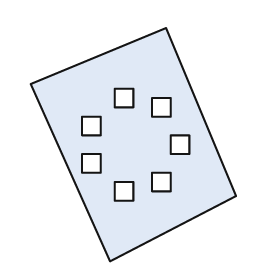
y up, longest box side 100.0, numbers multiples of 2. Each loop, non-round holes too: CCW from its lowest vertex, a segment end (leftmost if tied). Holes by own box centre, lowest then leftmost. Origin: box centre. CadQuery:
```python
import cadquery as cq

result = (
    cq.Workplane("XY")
    .moveTo(-10.0, -50.0)
    .lineTo(44.0, -22.0)
    .lineTo(14.0, 50.0)
    .lineTo(-44.0, 26.0)
    .close()
    .moveTo(-8.0, -24.0)
    .lineTo(0.0, -24.0)
    .lineTo(0.0, -16.0)
    .lineTo(-8.0, -16.0)
    .close()
    .moveTo(8.0, -20.0)
    .lineTo(16.0, -20.0)
    .lineTo(16.0, -12.0)
    .lineTo(8.0, -12.0)
    .close()
    .moveTo(-22.0, -12.0)
    .lineTo(-14.0, -12.0)
    .lineTo(-14.0, -4.0)
    .lineTo(-22.0, -4.0)
    .close()
    .moveTo(16.0, -4.0)
    .lineTo(24.0, -4.0)
    .lineTo(24.0, 4.0)
    .lineTo(16.0, 4.0)
    .close()
    .moveTo(-22.0, 4.0)
    .lineTo(-14.0, 4.0)
    .lineTo(-14.0, 12.0)
    .lineTo(-22.0, 12.0)
    .close()
    .moveTo(8.0, 12.0)
    .lineTo(16.0, 12.0)
    .lineTo(16.0, 20.0)
    .lineTo(8.0, 20.0)
    .close()
    .moveTo(-8.0, 16.0)
    .lineTo(0.0, 16.0)
    .lineTo(0.0, 24.0)
    .lineTo(-8.0, 24.0)
    .close()
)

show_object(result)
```